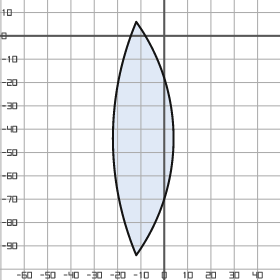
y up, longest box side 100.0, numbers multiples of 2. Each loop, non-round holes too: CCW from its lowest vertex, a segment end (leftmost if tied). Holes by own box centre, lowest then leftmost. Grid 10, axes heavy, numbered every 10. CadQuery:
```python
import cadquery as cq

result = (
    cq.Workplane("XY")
    .moveTo(-12.0, -94.0)
    .threePointArc((4.0, -44.0), (-12.0, 6.0))
    .threePointArc((-22.0, -44.0), (-12.0, -94.0))
    .close()
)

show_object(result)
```